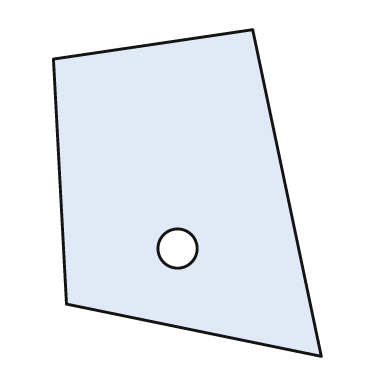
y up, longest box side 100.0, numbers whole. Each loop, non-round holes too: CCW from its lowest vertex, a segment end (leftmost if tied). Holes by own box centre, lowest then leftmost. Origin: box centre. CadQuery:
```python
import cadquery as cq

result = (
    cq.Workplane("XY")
    .moveTo(41.0, -50.0)
    .lineTo(20.0, 50.0)
    .lineTo(-41.0, 41.0)
    .lineTo(-37.0, -34.0)
    .close()
    .moveTo(-3.0, -17.0)
    .circle(6.0)
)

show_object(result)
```